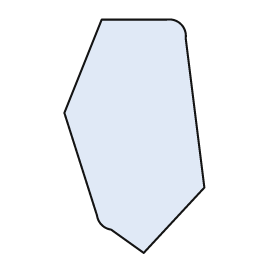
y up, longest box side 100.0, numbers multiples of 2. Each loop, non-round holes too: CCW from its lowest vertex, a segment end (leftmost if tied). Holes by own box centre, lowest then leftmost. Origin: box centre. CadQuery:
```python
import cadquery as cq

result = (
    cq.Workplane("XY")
    .moveTo(4.0, -50.0)
    .lineTo(30.0, -22.0)
    .lineTo(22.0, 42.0)
    .threePointArc((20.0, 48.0), (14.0, 50.0))
    .lineTo(-14.0, 50.0)
    .lineTo(-30.0, 10.0)
    .lineTo(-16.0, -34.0)
    .threePointArc((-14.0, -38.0), (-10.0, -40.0))
    .close()
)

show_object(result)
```